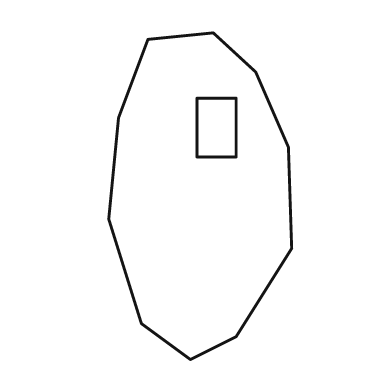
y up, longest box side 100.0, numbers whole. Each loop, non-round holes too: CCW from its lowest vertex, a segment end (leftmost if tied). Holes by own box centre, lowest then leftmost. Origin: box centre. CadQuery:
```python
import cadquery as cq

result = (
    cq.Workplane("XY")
    .moveTo(-3.0, -50.0)
    .lineTo(11.0, -43.0)
    .lineTo(28.0, -16.0)
    .lineTo(27.0, 15.0)
    .lineTo(17.0, 38.0)
    .lineTo(4.0, 50.0)
    .lineTo(-16.0, 48.0)
    .lineTo(-25.0, 24.0)
    .lineTo(-28.0, -7.0)
    .lineTo(-18.0, -39.0)
    .close()
    .moveTo(-1.0, 12.0)
    .lineTo(11.0, 12.0)
    .lineTo(11.0, 30.0)
    .lineTo(-1.0, 30.0)
    .close()
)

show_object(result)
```